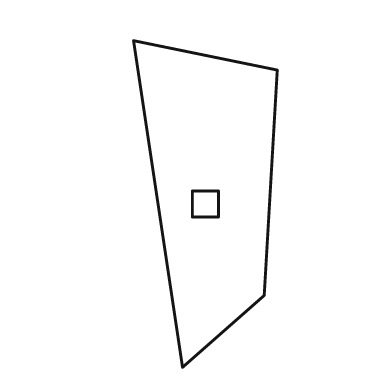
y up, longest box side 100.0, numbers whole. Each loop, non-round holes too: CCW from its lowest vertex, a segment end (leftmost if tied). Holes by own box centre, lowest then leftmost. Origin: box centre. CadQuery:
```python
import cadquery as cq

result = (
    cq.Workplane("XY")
    .moveTo(-7.0, -50.0)
    .lineTo(18.0, -28.0)
    .lineTo(22.0, 41.0)
    .lineTo(-22.0, 50.0)
    .close()
    .moveTo(-4.0, -4.0)
    .lineTo(4.0, -4.0)
    .lineTo(4.0, 4.0)
    .lineTo(-4.0, 4.0)
    .close()
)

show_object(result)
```